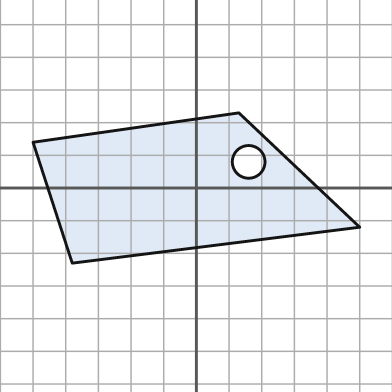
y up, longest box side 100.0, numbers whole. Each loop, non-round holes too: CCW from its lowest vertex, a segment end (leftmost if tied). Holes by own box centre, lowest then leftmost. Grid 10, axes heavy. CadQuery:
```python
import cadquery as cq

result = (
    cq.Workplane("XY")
    .moveTo(-38.0, -23.0)
    .lineTo(50.0, -12.0)
    .lineTo(13.0, 23.0)
    .lineTo(-50.0, 14.0)
    .close()
    .moveTo(16.0, 8.0)
    .circle(5.0)
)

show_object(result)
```